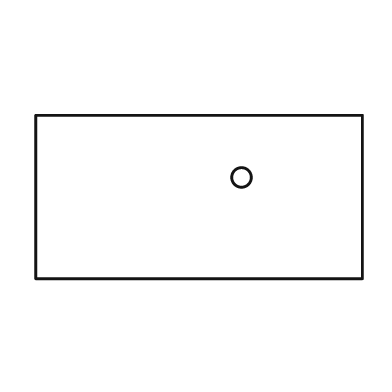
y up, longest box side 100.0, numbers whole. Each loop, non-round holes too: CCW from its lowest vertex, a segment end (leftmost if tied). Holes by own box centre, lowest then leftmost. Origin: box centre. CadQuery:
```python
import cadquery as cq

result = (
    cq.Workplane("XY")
    .moveTo(-50.0, -25.0)
    .lineTo(50.0, -25.0)
    .lineTo(50.0, 25.0)
    .lineTo(-50.0, 25.0)
    .close()
    .moveTo(13.0, 6.0)
    .circle(3.0)
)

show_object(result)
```